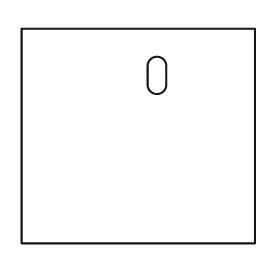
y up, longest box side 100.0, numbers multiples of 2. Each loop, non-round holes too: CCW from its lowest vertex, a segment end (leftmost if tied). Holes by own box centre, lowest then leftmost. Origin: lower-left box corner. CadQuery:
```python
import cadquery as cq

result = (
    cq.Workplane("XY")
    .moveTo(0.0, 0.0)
    .lineTo(100.0, 0.0)
    .lineTo(100.0, 92.0)
    .lineTo(0.0, 92.0)
    .close()
    .moveTo(54.0, 68.0)
    .threePointArc((58.0, 64.0), (62.0, 68.0))
    .lineTo(62.0, 76.0)
    .threePointArc((58.0, 80.0), (54.0, 76.0))
    .close()
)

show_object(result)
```